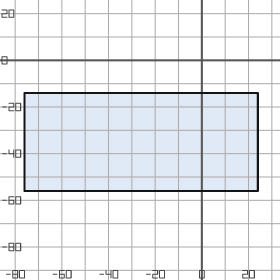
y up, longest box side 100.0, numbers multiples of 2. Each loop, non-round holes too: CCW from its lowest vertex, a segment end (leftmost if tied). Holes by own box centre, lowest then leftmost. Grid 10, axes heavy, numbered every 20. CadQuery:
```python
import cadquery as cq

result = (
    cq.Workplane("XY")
    .moveTo(-76.0, -56.0)
    .lineTo(24.0, -56.0)
    .lineTo(24.0, -14.0)
    .lineTo(-76.0, -14.0)
    .close()
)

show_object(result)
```